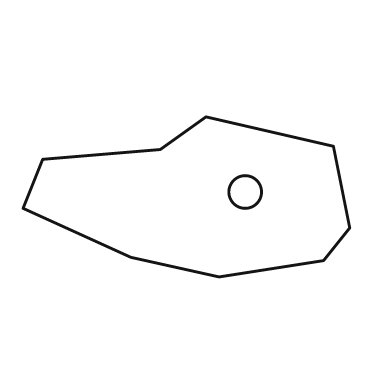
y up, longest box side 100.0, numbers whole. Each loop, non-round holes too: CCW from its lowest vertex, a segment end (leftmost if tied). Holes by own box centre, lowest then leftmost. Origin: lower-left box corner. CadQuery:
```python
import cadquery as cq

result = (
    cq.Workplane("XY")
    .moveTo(60.0, 0.0)
    .lineTo(92.0, 5.0)
    .lineTo(100.0, 15.0)
    .lineTo(95.0, 40.0)
    .lineTo(56.0, 49.0)
    .lineTo(42.0, 39.0)
    .lineTo(6.0, 36.0)
    .lineTo(0.0, 21.0)
    .lineTo(33.0, 6.0)
    .close()
    .moveTo(68.0, 26.0)
    .circle(5.0)
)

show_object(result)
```